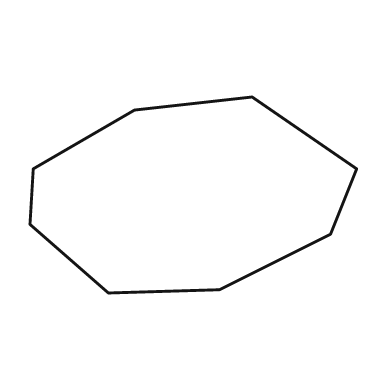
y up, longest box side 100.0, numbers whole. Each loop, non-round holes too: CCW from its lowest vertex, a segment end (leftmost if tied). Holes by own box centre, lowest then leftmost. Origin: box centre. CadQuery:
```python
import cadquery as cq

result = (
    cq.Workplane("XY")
    .moveTo(-26.0, -30.0)
    .lineTo(8.0, -29.0)
    .lineTo(42.0, -12.0)
    .lineTo(50.0, 8.0)
    .lineTo(18.0, 30.0)
    .lineTo(-18.0, 26.0)
    .lineTo(-49.0, 8.0)
    .lineTo(-50.0, -9.0)
    .close()
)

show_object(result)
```